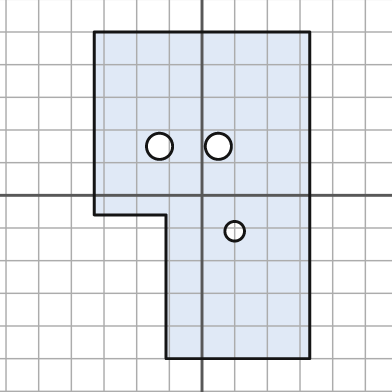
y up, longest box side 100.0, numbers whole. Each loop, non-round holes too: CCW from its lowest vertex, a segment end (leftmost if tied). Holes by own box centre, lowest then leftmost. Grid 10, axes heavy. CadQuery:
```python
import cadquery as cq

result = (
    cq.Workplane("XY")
    .moveTo(-11.0, -50.0)
    .lineTo(33.0, -50.0)
    .lineTo(33.0, 50.0)
    .lineTo(-33.0, 50.0)
    .lineTo(-33.0, -6.0)
    .lineTo(-11.0, -6.0)
    .close()
    .moveTo(10.0, -11.0)
    .circle(3.0)
    .moveTo(-13.0, 15.0)
    .circle(4.0)
    .moveTo(5.0, 15.0)
    .circle(4.0)
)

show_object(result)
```